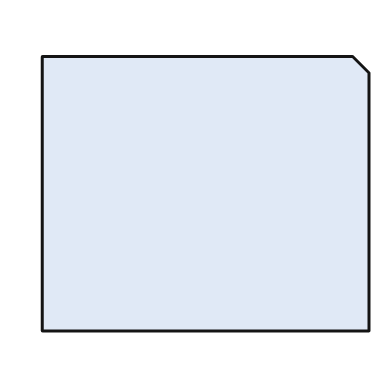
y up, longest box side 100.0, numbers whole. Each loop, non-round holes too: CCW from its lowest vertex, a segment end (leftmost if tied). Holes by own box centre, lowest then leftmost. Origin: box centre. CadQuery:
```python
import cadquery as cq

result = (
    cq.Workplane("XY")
    .moveTo(-50.0, -42.0)
    .lineTo(50.0, -42.0)
    .lineTo(50.0, 37.0)
    .lineTo(45.0, 42.0)
    .lineTo(-50.0, 42.0)
    .close()
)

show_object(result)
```